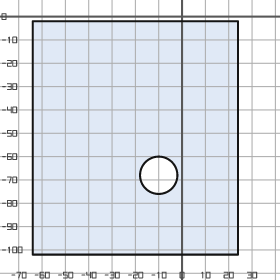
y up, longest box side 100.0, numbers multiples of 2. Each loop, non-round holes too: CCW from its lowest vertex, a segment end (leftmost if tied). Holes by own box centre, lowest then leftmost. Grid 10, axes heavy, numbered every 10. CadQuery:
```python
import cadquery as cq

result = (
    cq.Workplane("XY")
    .moveTo(-64.0, -102.0)
    .lineTo(24.0, -102.0)
    .lineTo(24.0, -2.0)
    .lineTo(-64.0, -2.0)
    .close()
    .moveTo(-10.0, -68.0)
    .circle(8.0)
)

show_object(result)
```